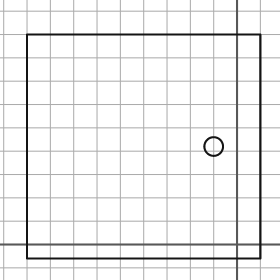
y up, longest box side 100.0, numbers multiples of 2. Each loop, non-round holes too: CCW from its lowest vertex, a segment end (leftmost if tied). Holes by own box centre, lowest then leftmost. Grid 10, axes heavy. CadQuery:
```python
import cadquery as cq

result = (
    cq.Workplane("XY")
    .moveTo(-90.0, -6.0)
    .lineTo(10.0, -6.0)
    .lineTo(10.0, 90.0)
    .lineTo(-90.0, 90.0)
    .close()
    .moveTo(-10.0, 42.0)
    .circle(4.0)
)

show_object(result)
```